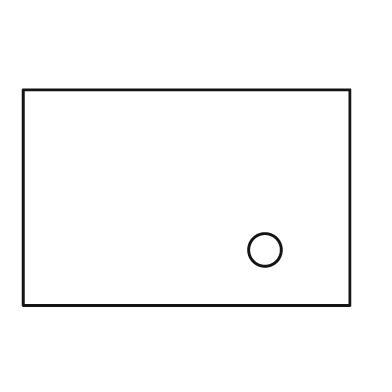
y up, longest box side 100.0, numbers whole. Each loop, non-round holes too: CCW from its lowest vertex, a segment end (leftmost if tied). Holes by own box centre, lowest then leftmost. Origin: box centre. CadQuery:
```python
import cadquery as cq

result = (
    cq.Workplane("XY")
    .moveTo(-50.0, -33.0)
    .lineTo(50.0, -33.0)
    .lineTo(50.0, 33.0)
    .lineTo(-50.0, 33.0)
    .close()
    .moveTo(24.0, -16.0)
    .circle(5.0)
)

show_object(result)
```